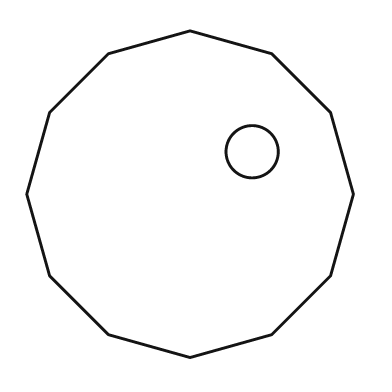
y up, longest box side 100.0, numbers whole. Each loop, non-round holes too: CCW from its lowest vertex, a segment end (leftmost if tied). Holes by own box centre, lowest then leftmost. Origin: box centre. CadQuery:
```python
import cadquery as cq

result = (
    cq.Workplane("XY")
    .moveTo(0.0, -50.0)
    .lineTo(25.0, -43.0)
    .lineTo(43.0, -25.0)
    .lineTo(50.0, 0.0)
    .lineTo(43.0, 25.0)
    .lineTo(25.0, 43.0)
    .lineTo(0.0, 50.0)
    .lineTo(-25.0, 43.0)
    .lineTo(-43.0, 25.0)
    .lineTo(-50.0, 0.0)
    .lineTo(-43.0, -25.0)
    .lineTo(-25.0, -43.0)
    .close()
    .moveTo(19.0, 13.0)
    .circle(8.0)
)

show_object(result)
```